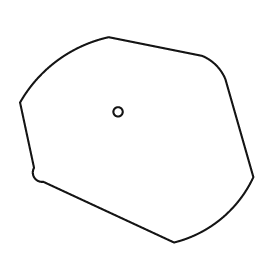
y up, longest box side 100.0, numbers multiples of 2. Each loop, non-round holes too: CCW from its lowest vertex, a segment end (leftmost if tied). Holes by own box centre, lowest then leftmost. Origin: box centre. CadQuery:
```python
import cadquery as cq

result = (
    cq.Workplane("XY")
    .moveTo(16.0, -44.0)
    .threePointArc((36.0, -34.0), (50.0, -16.0))
    .lineTo(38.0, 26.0)
    .threePointArc((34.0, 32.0), (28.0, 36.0))
    .lineTo(-12.0, 44.0)
    .threePointArc((-34.0, 34.0), (-50.0, 16.0))
    .lineTo(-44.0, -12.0)
    .threePointArc((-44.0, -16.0), (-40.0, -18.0))
    .close()
    .moveTo(-8.0, 12.0)
    .circle(2.0)
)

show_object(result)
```